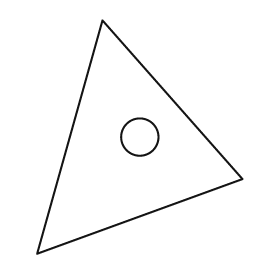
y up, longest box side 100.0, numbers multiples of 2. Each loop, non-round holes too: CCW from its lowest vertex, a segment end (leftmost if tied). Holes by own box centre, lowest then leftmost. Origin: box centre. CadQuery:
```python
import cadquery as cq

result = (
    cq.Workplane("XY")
    .moveTo(-44.0, -50.0)
    .lineTo(44.0, -18.0)
    .lineTo(-16.0, 50.0)
    .close()
    .moveTo(0.0, 0.0)
    .circle(8.0)
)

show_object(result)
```